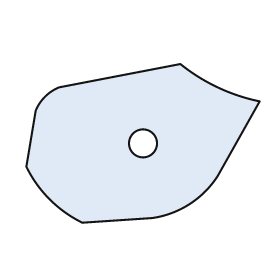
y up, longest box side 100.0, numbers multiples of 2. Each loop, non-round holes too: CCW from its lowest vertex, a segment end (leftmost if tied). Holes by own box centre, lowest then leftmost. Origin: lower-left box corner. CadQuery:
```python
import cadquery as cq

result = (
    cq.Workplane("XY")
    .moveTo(24.0, 0.0)
    .lineTo(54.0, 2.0)
    .threePointArc((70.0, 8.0), (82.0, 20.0))
    .lineTo(100.0, 52.0)
    .threePointArc((82.0, 58.0), (66.0, 68.0))
    .lineTo(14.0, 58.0)
    .threePointArc((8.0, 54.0), (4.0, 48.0))
    .lineTo(0.0, 24.0)
    .threePointArc((10.0, 10.0), (24.0, 0.0))
    .close()
    .moveTo(50.0, 34.0)
    .circle(6.0)
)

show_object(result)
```